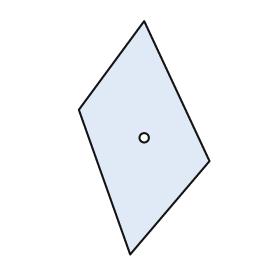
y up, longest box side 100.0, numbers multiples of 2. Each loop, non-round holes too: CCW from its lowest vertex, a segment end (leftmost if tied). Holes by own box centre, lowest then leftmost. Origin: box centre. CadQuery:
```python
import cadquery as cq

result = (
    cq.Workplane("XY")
    .moveTo(-6.0, -50.0)
    .lineTo(28.0, -10.0)
    .lineTo(0.0, 50.0)
    .lineTo(-28.0, 12.0)
    .close()
    .moveTo(0.0, 0.0)
    .circle(2.0)
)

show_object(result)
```